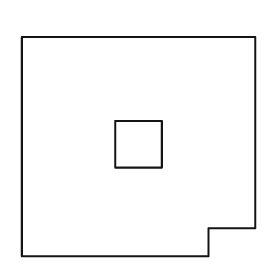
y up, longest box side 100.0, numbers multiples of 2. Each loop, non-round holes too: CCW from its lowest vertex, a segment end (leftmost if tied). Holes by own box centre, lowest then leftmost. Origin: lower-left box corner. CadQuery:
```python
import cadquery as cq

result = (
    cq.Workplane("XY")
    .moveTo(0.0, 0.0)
    .lineTo(80.0, 0.0)
    .lineTo(80.0, 12.0)
    .lineTo(100.0, 12.0)
    .lineTo(100.0, 94.0)
    .lineTo(0.0, 94.0)
    .close()
    .moveTo(40.0, 38.0)
    .lineTo(60.0, 38.0)
    .lineTo(60.0, 58.0)
    .lineTo(40.0, 58.0)
    .close()
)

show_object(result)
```